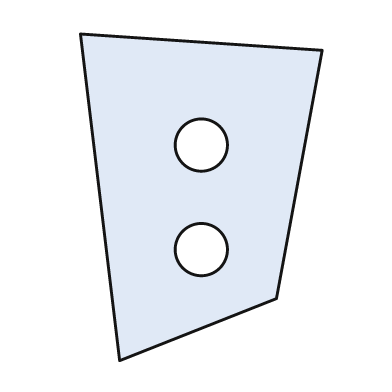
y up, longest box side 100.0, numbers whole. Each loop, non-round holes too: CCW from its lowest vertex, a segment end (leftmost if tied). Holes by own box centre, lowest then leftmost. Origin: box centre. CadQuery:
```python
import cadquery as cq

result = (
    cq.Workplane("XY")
    .moveTo(-25.0, -50.0)
    .lineTo(23.0, -31.0)
    .lineTo(37.0, 45.0)
    .lineTo(-37.0, 50.0)
    .close()
    .moveTo(0.0, -16.0)
    .circle(8.0)
    .moveTo(0.0, 16.0)
    .circle(8.0)
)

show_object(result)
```